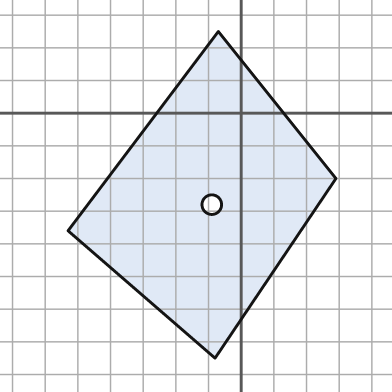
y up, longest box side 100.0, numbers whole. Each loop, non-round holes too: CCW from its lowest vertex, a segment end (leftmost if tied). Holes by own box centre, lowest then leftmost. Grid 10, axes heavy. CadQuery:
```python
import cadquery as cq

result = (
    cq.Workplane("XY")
    .moveTo(-8.0, -75.0)
    .lineTo(29.0, -20.0)
    .lineTo(-7.0, 25.0)
    .lineTo(-53.0, -36.0)
    .close()
    .moveTo(-9.0, -28.0)
    .circle(3.0)
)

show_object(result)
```